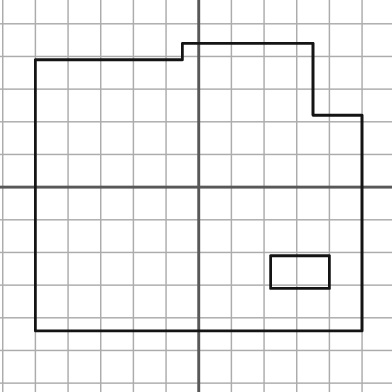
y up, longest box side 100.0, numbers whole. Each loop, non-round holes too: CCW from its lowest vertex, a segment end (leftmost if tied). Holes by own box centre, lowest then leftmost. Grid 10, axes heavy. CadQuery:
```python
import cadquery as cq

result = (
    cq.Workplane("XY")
    .moveTo(-50.0, -44.0)
    .lineTo(50.0, -44.0)
    .lineTo(50.0, 22.0)
    .lineTo(35.0, 22.0)
    .lineTo(35.0, 44.0)
    .lineTo(-5.0, 44.0)
    .lineTo(-5.0, 39.0)
    .lineTo(-50.0, 39.0)
    .close()
    .moveTo(22.0, -31.0)
    .lineTo(40.0, -31.0)
    .lineTo(40.0, -21.0)
    .lineTo(22.0, -21.0)
    .close()
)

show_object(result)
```